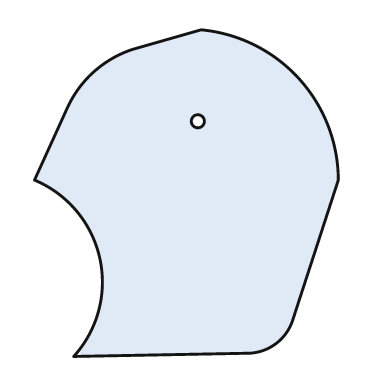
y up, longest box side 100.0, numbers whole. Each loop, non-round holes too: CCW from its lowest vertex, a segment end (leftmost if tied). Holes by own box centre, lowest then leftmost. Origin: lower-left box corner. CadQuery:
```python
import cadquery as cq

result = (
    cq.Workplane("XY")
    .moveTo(12.0, 0.0)
    .lineTo(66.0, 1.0)
    .threePointArc((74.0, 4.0), (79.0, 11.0))
    .lineTo(93.0, 54.0)
    .threePointArc((81.0, 85.0), (51.0, 100.0))
    .lineTo(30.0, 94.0)
    .threePointArc((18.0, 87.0), (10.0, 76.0))
    .lineTo(0.0, 54.0)
    .threePointArc((20.0, 30.0), (12.0, 0.0))
    .close()
    .moveTo(50.0, 72.0)
    .circle(2.0)
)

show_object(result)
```